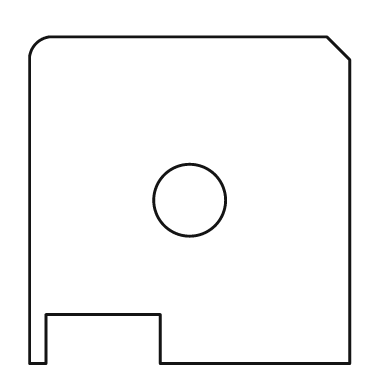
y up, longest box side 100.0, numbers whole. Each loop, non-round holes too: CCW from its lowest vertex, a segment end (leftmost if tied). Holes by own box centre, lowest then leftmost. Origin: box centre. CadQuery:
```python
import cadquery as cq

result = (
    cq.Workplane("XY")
    .moveTo(-49.0, -50.0)
    .lineTo(-44.0, -50.0)
    .lineTo(-44.0, -35.0)
    .lineTo(-9.0, -35.0)
    .lineTo(-9.0, -50.0)
    .lineTo(49.0, -50.0)
    .lineTo(49.0, 43.0)
    .lineTo(42.0, 50.0)
    .lineTo(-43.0, 50.0)
    .threePointArc((-47.0, 48.0), (-49.0, 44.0))
    .close()
    .moveTo(0.0, 0.0)
    .circle(11.0)
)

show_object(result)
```